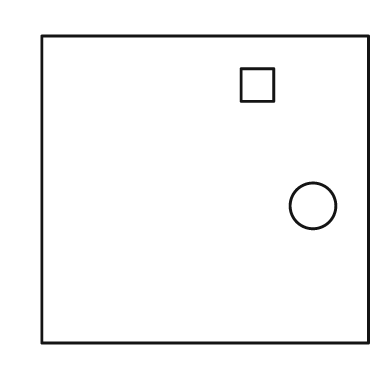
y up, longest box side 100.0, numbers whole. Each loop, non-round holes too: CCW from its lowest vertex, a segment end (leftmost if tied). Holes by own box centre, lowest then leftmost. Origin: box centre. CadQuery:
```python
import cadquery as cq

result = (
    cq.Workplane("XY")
    .moveTo(-50.0, -47.0)
    .lineTo(50.0, -47.0)
    .lineTo(50.0, 47.0)
    .lineTo(-50.0, 47.0)
    .close()
    .moveTo(33.0, -5.0)
    .circle(7.0)
    .moveTo(11.0, 27.0)
    .lineTo(21.0, 27.0)
    .lineTo(21.0, 37.0)
    .lineTo(11.0, 37.0)
    .close()
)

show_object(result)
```